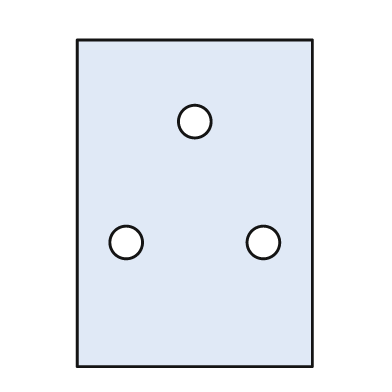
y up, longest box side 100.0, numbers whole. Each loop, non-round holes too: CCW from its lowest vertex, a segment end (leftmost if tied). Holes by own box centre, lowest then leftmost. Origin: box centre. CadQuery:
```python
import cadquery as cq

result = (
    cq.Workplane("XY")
    .moveTo(-36.0, -50.0)
    .lineTo(36.0, -50.0)
    .lineTo(36.0, 50.0)
    .lineTo(-36.0, 50.0)
    .close()
    .moveTo(-21.0, -12.0)
    .circle(5.0)
    .moveTo(21.0, -12.0)
    .circle(5.0)
    .moveTo(0.0, 25.0)
    .circle(5.0)
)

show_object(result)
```